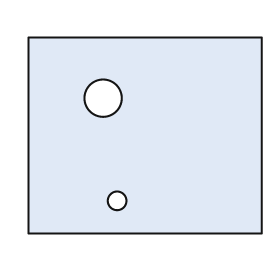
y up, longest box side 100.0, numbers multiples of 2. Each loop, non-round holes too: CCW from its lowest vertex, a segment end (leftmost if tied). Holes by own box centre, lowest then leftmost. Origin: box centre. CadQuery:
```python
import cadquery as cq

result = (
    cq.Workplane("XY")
    .moveTo(-50.0, -42.0)
    .lineTo(50.0, -42.0)
    .lineTo(50.0, 42.0)
    .lineTo(-50.0, 42.0)
    .close()
    .moveTo(-12.0, -28.0)
    .circle(4.0)
    .moveTo(-18.0, 16.0)
    .circle(8.0)
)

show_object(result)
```